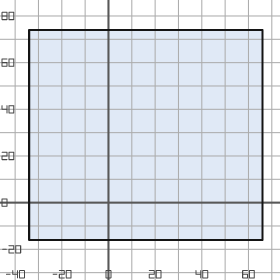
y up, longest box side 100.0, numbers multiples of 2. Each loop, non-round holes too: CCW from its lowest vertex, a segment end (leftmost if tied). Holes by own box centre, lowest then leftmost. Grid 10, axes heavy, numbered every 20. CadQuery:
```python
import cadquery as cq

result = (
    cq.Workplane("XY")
    .moveTo(-34.0, -16.0)
    .lineTo(66.0, -16.0)
    .lineTo(66.0, 74.0)
    .lineTo(-34.0, 74.0)
    .close()
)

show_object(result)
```